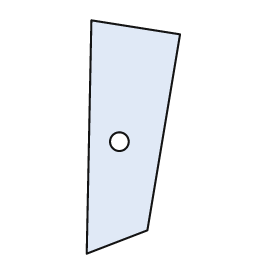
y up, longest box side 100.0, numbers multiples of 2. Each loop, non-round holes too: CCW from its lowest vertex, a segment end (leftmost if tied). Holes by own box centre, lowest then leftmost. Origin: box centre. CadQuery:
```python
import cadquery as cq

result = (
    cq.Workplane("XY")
    .moveTo(-20.0, -50.0)
    .lineTo(6.0, -40.0)
    .lineTo(20.0, 44.0)
    .lineTo(-18.0, 50.0)
    .close()
    .moveTo(-6.0, -2.0)
    .circle(4.0)
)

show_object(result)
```